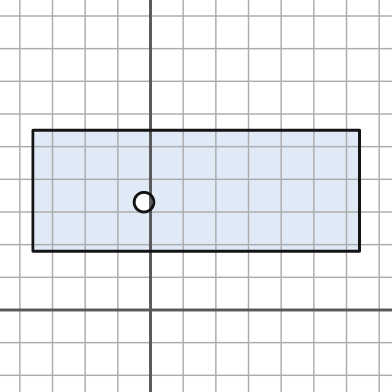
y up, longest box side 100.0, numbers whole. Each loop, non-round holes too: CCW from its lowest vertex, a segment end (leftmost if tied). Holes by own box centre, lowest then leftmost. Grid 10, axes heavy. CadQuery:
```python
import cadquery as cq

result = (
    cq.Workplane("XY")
    .moveTo(-36.0, 18.0)
    .lineTo(64.0, 18.0)
    .lineTo(64.0, 55.0)
    .lineTo(-36.0, 55.0)
    .close()
    .moveTo(-2.0, 33.0)
    .circle(3.0)
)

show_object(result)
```